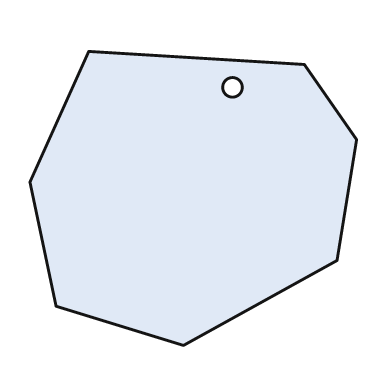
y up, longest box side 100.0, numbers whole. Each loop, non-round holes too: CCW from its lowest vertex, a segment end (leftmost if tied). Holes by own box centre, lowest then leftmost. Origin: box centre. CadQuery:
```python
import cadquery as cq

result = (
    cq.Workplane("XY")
    .moveTo(-3.0, -45.0)
    .lineTo(44.0, -19.0)
    .lineTo(50.0, 18.0)
    .lineTo(34.0, 41.0)
    .lineTo(-32.0, 45.0)
    .lineTo(-50.0, 5.0)
    .lineTo(-42.0, -33.0)
    .close()
    .moveTo(12.0, 34.0)
    .circle(3.0)
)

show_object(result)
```